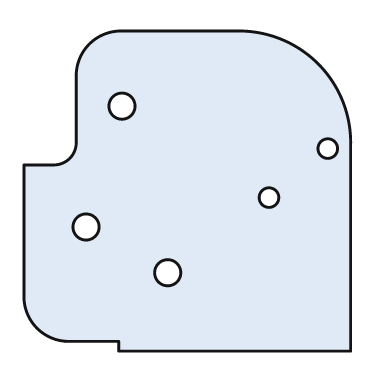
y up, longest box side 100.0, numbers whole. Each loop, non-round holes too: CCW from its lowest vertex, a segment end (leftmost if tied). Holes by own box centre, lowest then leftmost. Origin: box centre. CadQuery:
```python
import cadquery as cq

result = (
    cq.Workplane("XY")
    .moveTo(-21.0, -49.0)
    .lineTo(50.0, -49.0)
    .lineTo(50.0, 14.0)
    .threePointArc((40.0, 39.0), (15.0, 49.0))
    .lineTo(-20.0, 49.0)
    .threePointArc((-30.0, 45.0), (-34.0, 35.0))
    .lineTo(-34.0, 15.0)
    .threePointArc((-36.0, 10.0), (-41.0, 8.0))
    .lineTo(-50.0, 8.0)
    .lineTo(-50.0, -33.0)
    .threePointArc((-46.0, -42.0), (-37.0, -46.0))
    .lineTo(-21.0, -46.0)
    .close()
    .moveTo(-6.0, -25.0)
    .circle(4.0)
    .moveTo(-31.0, -11.0)
    .circle(4.0)
    .moveTo(25.0, -2.0)
    .circle(3.0)
    .moveTo(43.0, 13.0)
    .circle(3.0)
    .moveTo(-20.0, 26.0)
    .circle(4.0)
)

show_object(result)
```